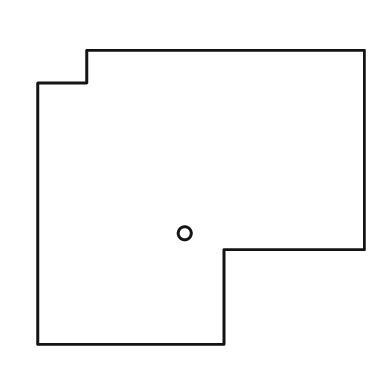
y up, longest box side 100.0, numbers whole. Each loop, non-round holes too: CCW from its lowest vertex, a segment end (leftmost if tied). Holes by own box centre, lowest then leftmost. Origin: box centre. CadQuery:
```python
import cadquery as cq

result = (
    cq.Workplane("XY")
    .moveTo(-50.0, -45.0)
    .lineTo(7.0, -45.0)
    .lineTo(7.0, -16.0)
    .lineTo(50.0, -16.0)
    .lineTo(50.0, 45.0)
    .lineTo(-35.0, 45.0)
    .lineTo(-35.0, 35.0)
    .lineTo(-50.0, 35.0)
    .close()
    .moveTo(-5.0, -11.0)
    .circle(2.0)
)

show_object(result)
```